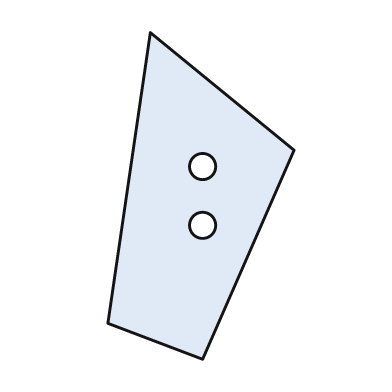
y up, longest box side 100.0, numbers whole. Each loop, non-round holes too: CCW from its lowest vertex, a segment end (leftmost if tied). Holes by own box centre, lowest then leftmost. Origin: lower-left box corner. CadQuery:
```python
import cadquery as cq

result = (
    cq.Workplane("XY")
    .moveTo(29.0, 0.0)
    .lineTo(57.0, 64.0)
    .lineTo(13.0, 100.0)
    .lineTo(0.0, 11.0)
    .close()
    .moveTo(29.0, 41.0)
    .circle(4.0)
    .moveTo(29.0, 59.0)
    .circle(4.0)
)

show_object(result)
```